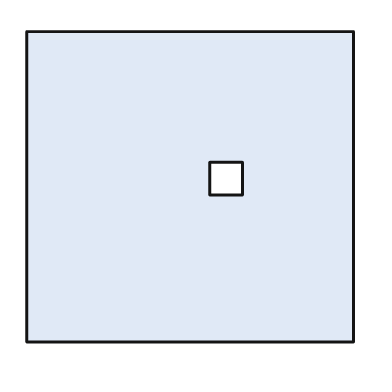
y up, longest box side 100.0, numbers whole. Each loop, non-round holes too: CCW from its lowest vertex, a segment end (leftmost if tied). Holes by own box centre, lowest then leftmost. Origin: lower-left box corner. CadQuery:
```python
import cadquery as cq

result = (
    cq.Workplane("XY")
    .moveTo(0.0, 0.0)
    .lineTo(100.0, 0.0)
    .lineTo(100.0, 95.0)
    .lineTo(0.0, 95.0)
    .close()
    .moveTo(56.0, 45.0)
    .lineTo(66.0, 45.0)
    .lineTo(66.0, 55.0)
    .lineTo(56.0, 55.0)
    .close()
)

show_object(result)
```